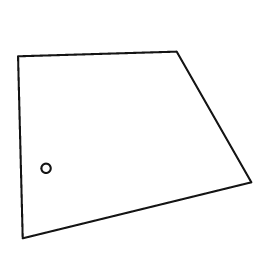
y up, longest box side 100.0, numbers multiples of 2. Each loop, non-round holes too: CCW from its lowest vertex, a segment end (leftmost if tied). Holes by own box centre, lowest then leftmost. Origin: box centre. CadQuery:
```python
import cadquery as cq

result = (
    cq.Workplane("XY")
    .moveTo(-48.0, -40.0)
    .lineTo(50.0, -16.0)
    .lineTo(18.0, 40.0)
    .lineTo(-50.0, 38.0)
    .close()
    .moveTo(-38.0, -10.0)
    .circle(2.0)
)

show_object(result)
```